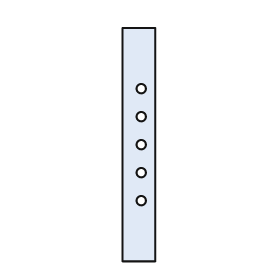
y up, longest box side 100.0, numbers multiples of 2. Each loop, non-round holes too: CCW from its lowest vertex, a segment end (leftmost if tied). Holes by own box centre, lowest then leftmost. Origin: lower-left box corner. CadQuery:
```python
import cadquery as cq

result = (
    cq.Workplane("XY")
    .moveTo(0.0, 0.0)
    .lineTo(14.0, 0.0)
    .lineTo(14.0, 100.0)
    .lineTo(0.0, 100.0)
    .close()
    .moveTo(8.0, 26.0)
    .circle(2.0)
    .moveTo(8.0, 38.0)
    .circle(2.0)
    .moveTo(8.0, 50.0)
    .circle(2.0)
    .moveTo(8.0, 62.0)
    .circle(2.0)
    .moveTo(8.0, 74.0)
    .circle(2.0)
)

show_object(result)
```